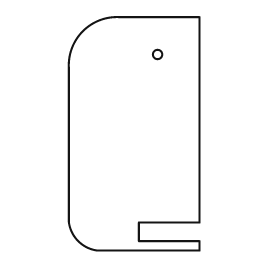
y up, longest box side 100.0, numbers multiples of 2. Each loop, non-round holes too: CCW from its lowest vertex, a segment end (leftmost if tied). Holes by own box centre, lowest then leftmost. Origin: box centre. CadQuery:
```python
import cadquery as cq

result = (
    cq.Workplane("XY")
    .moveTo(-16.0, -50.0)
    .lineTo(28.0, -50.0)
    .lineTo(28.0, -46.0)
    .lineTo(2.0, -46.0)
    .lineTo(2.0, -38.0)
    .lineTo(28.0, -38.0)
    .lineTo(28.0, 50.0)
    .lineTo(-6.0, 50.0)
    .threePointArc((-22.0, 44.0), (-28.0, 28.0))
    .lineTo(-28.0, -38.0)
    .threePointArc((-24.0, -46.0), (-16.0, -50.0))
    .close()
    .moveTo(10.0, 34.0)
    .circle(2.0)
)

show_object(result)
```